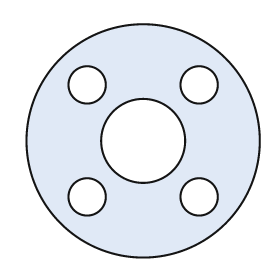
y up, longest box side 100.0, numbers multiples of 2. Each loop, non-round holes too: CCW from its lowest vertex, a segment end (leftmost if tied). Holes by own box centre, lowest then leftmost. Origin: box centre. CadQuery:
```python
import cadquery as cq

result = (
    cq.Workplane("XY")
    .moveTo(0.0, 0.0)
    .circle(50.0)
    .moveTo(-24.0, -24.0)
    .circle(8.0)
    .moveTo(24.0, -24.0)
    .circle(8.0)
    .moveTo(0.0, 0.0)
    .circle(18.0)
    .moveTo(-24.0, 24.0)
    .circle(8.0)
    .moveTo(24.0, 24.0)
    .circle(8.0)
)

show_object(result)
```